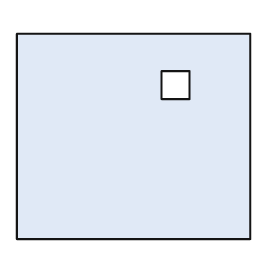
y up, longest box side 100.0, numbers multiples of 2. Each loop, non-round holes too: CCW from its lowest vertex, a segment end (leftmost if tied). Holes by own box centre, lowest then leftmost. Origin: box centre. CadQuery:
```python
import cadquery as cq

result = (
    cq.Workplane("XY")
    .moveTo(-50.0, -44.0)
    .lineTo(50.0, -44.0)
    .lineTo(50.0, 44.0)
    .lineTo(-50.0, 44.0)
    .close()
    .moveTo(12.0, 16.0)
    .lineTo(24.0, 16.0)
    .lineTo(24.0, 28.0)
    .lineTo(12.0, 28.0)
    .close()
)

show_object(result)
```